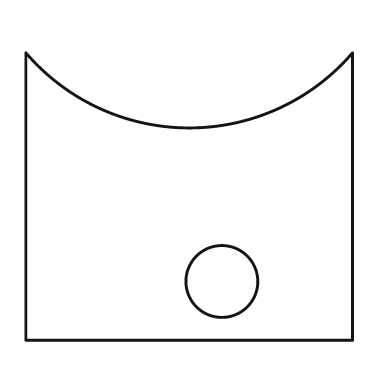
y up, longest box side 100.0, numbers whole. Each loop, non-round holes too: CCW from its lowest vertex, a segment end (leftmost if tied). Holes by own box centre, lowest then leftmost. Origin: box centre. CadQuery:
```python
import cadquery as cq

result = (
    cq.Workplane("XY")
    .moveTo(-50.0, -44.0)
    .lineTo(50.0, -44.0)
    .lineTo(50.0, 44.0)
    .threePointArc((0.0, 21.0), (-50.0, 44.0))
    .close()
    .moveTo(10.0, -26.0)
    .circle(11.0)
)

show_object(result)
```